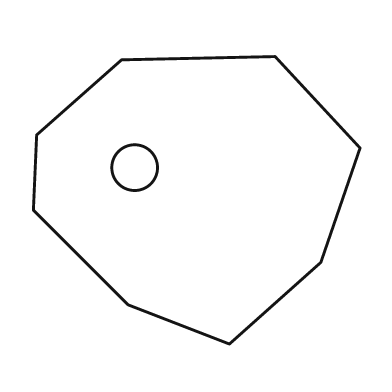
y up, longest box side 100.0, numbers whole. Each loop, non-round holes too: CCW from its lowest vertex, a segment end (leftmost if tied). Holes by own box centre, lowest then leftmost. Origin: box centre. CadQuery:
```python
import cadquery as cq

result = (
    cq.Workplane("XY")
    .moveTo(10.0, -44.0)
    .lineTo(38.0, -19.0)
    .lineTo(50.0, 16.0)
    .lineTo(24.0, 44.0)
    .lineTo(-23.0, 43.0)
    .lineTo(-49.0, 20.0)
    .lineTo(-50.0, -3.0)
    .lineTo(-21.0, -32.0)
    .close()
    .moveTo(-19.0, 10.0)
    .circle(7.0)
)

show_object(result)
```